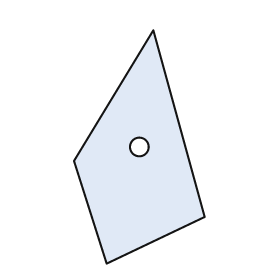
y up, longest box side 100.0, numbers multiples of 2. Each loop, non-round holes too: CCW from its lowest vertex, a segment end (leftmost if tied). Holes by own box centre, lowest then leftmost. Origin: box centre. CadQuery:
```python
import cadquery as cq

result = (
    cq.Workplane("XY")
    .moveTo(-14.0, -50.0)
    .lineTo(28.0, -30.0)
    .lineTo(6.0, 50.0)
    .lineTo(-28.0, -6.0)
    .close()
    .moveTo(0.0, 0.0)
    .circle(4.0)
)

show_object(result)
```